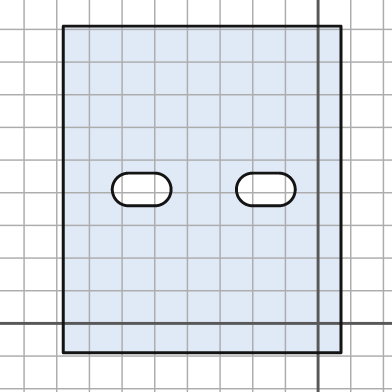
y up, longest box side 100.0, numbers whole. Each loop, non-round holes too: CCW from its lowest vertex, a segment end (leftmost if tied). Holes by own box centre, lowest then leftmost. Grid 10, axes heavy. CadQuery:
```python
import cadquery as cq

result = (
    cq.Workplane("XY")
    .moveTo(-78.0, -9.0)
    .lineTo(7.0, -9.0)
    .lineTo(7.0, 91.0)
    .lineTo(-78.0, 91.0)
    .close()
    .moveTo(-58.0, 36.0)
    .lineTo(-50.0, 36.0)
    .threePointArc((-45.0, 41.0), (-50.0, 46.0))
    .lineTo(-58.0, 46.0)
    .threePointArc((-63.0, 41.0), (-58.0, 36.0))
    .close()
    .moveTo(-20.0, 36.0)
    .lineTo(-12.0, 36.0)
    .threePointArc((-7.0, 41.0), (-12.0, 46.0))
    .lineTo(-20.0, 46.0)
    .threePointArc((-25.0, 41.0), (-20.0, 36.0))
    .close()
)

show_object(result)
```